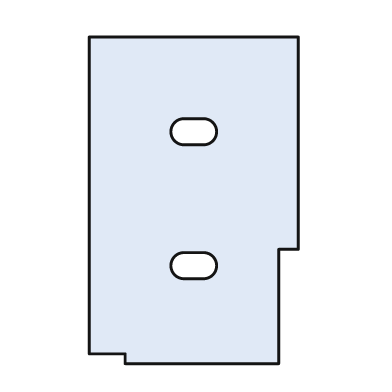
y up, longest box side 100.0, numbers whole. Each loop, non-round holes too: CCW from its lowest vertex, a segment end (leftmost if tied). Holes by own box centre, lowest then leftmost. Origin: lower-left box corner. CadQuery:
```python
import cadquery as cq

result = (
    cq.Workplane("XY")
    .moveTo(11.0, 0.0)
    .lineTo(58.0, 0.0)
    .lineTo(58.0, 35.0)
    .lineTo(64.0, 35.0)
    .lineTo(64.0, 100.0)
    .lineTo(0.0, 100.0)
    .lineTo(0.0, 3.0)
    .lineTo(11.0, 3.0)
    .close()
    .moveTo(29.0, 26.0)
    .lineTo(35.0, 26.0)
    .threePointArc((39.0, 30.0), (35.0, 34.0))
    .lineTo(29.0, 34.0)
    .threePointArc((25.0, 30.0), (29.0, 26.0))
    .close()
    .moveTo(29.0, 67.0)
    .lineTo(35.0, 67.0)
    .threePointArc((39.0, 71.0), (35.0, 75.0))
    .lineTo(29.0, 75.0)
    .threePointArc((25.0, 71.0), (29.0, 67.0))
    .close()
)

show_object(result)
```